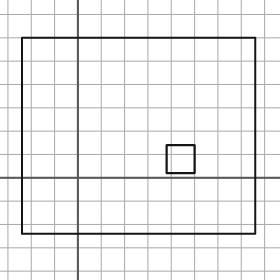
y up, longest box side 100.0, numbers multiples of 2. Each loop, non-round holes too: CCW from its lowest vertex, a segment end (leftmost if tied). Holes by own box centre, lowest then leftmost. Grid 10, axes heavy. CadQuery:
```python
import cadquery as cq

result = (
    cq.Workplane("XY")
    .moveTo(-24.0, -24.0)
    .lineTo(76.0, -24.0)
    .lineTo(76.0, 60.0)
    .lineTo(-24.0, 60.0)
    .close()
    .moveTo(38.0, 2.0)
    .lineTo(50.0, 2.0)
    .lineTo(50.0, 14.0)
    .lineTo(38.0, 14.0)
    .close()
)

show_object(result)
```